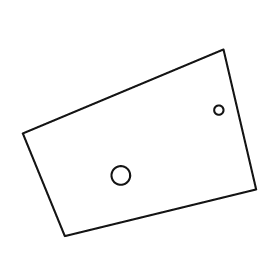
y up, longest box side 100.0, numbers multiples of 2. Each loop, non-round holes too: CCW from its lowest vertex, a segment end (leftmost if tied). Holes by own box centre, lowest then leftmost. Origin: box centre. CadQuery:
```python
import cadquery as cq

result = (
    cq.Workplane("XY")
    .moveTo(-32.0, -40.0)
    .lineTo(50.0, -20.0)
    .lineTo(36.0, 40.0)
    .lineTo(-50.0, 4.0)
    .close()
    .moveTo(-8.0, -14.0)
    .circle(4.0)
    .moveTo(34.0, 14.0)
    .circle(2.0)
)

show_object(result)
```